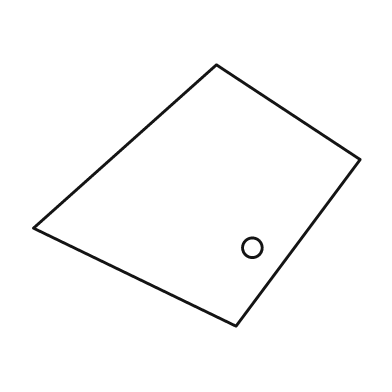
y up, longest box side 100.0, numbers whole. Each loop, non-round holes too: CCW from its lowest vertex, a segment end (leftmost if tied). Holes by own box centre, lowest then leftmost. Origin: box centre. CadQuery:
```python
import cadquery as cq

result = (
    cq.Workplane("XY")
    .moveTo(12.0, -40.0)
    .lineTo(50.0, 11.0)
    .lineTo(6.0, 40.0)
    .lineTo(-50.0, -10.0)
    .close()
    .moveTo(17.0, -16.0)
    .circle(3.0)
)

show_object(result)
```